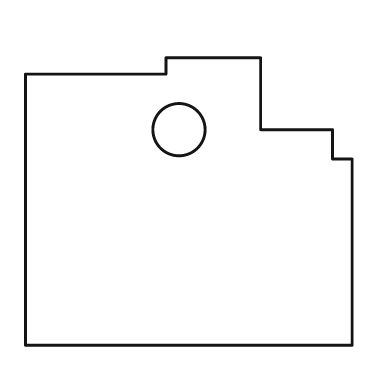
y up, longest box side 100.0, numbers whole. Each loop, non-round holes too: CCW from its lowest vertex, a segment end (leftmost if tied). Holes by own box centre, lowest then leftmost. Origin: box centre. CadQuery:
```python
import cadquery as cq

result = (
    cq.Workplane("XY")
    .moveTo(-50.0, -44.0)
    .lineTo(50.0, -44.0)
    .lineTo(50.0, 13.0)
    .lineTo(44.0, 13.0)
    .lineTo(44.0, 22.0)
    .lineTo(22.0, 22.0)
    .lineTo(22.0, 44.0)
    .lineTo(-7.0, 44.0)
    .lineTo(-7.0, 39.0)
    .lineTo(-50.0, 39.0)
    .close()
    .moveTo(-3.0, 22.0)
    .circle(8.0)
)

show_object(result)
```